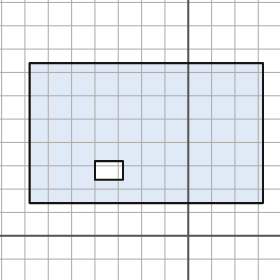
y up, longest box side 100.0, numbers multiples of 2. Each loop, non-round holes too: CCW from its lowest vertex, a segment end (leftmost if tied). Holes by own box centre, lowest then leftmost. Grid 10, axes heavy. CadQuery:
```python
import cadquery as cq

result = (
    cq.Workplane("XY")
    .moveTo(-68.0, 14.0)
    .lineTo(32.0, 14.0)
    .lineTo(32.0, 74.0)
    .lineTo(-68.0, 74.0)
    .close()
    .moveTo(-40.0, 24.0)
    .lineTo(-28.0, 24.0)
    .lineTo(-28.0, 32.0)
    .lineTo(-40.0, 32.0)
    .close()
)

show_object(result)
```